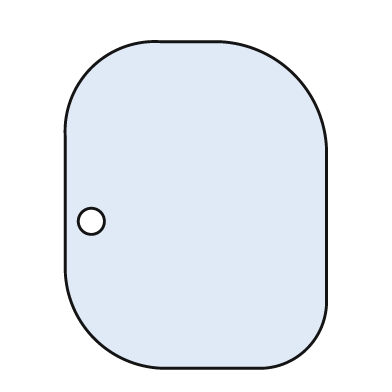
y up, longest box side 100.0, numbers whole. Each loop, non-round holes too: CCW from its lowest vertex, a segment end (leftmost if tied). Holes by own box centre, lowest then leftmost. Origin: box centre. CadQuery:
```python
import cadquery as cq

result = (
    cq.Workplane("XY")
    .moveTo(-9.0, -50.0)
    .lineTo(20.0, -50.0)
    .threePointArc((34.0, -44.0), (40.0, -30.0))
    .lineTo(40.0, 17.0)
    .threePointArc((30.0, 40.0), (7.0, 50.0))
    .lineTo(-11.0, 50.0)
    .threePointArc((-32.0, 42.0), (-40.0, 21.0))
    .lineTo(-40.0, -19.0)
    .threePointArc((-31.0, -41.0), (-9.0, -50.0))
    .close()
    .moveTo(-32.0, -5.0)
    .circle(4.0)
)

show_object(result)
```